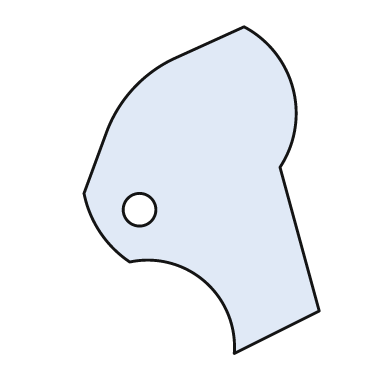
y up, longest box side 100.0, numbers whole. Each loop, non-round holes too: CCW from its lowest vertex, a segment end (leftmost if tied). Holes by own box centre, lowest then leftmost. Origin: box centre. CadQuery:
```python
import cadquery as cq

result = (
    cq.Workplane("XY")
    .moveTo(10.0, -50.0)
    .lineTo(36.0, -37.0)
    .lineTo(24.0, 7.0)
    .threePointArc((28.0, 31.0), (13.0, 50.0))
    .lineTo(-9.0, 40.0)
    .threePointArc((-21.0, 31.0), (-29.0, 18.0))
    .lineTo(-36.0, -1.0)
    .threePointArc((-31.0, -13.0), (-22.0, -22.0))
    .threePointArc((1.0, -28.0), (10.0, -50.0))
    .close()
    .moveTo(-19.0, -6.0)
    .circle(5.0)
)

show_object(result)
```